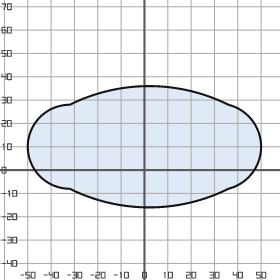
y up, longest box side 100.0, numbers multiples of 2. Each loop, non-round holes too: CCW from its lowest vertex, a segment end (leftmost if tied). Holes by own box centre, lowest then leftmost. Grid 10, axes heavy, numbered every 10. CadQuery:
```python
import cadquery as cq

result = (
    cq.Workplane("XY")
    .moveTo(-32.0, -8.0)
    .threePointArc((2.0, -16.0), (36.0, -8.0))
    .threePointArc((50.0, 10.0), (36.0, 28.0))
    .threePointArc((2.0, 36.0), (-32.0, 28.0))
    .threePointArc((-50.0, 10.0), (-32.0, -8.0))
    .close()
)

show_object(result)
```